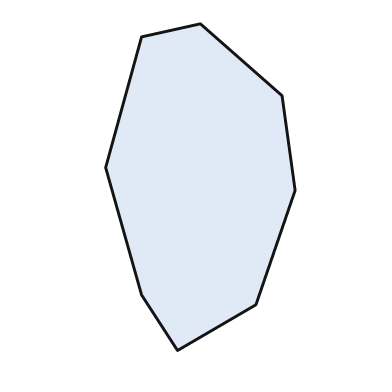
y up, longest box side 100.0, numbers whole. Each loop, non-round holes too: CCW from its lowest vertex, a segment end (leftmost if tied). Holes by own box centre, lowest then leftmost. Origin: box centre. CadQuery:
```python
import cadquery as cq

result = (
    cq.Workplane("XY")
    .moveTo(-7.0, -50.0)
    .lineTo(17.0, -36.0)
    .lineTo(29.0, -1.0)
    .lineTo(25.0, 28.0)
    .lineTo(0.0, 50.0)
    .lineTo(-18.0, 46.0)
    .lineTo(-29.0, 6.0)
    .lineTo(-18.0, -33.0)
    .close()
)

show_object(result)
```